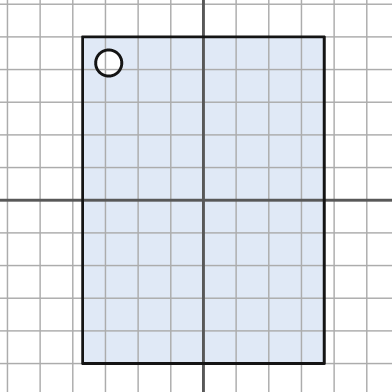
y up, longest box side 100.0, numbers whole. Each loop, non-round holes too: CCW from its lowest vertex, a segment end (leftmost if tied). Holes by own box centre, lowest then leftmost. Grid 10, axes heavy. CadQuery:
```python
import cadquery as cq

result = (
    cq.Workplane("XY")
    .moveTo(-37.0, -50.0)
    .lineTo(37.0, -50.0)
    .lineTo(37.0, 50.0)
    .lineTo(-37.0, 50.0)
    .close()
    .moveTo(-29.0, 42.0)
    .circle(4.0)
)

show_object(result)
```